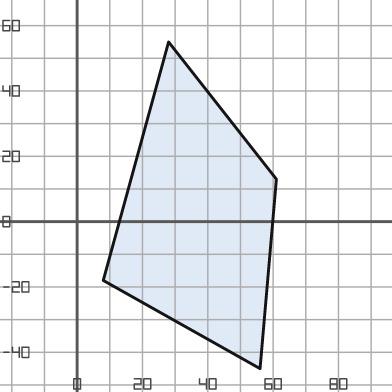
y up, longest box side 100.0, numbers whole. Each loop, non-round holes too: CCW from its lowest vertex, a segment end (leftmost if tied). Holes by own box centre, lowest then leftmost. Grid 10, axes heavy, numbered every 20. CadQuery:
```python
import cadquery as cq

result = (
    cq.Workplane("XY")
    .moveTo(56.0, -45.0)
    .lineTo(61.0, 13.0)
    .lineTo(28.0, 55.0)
    .lineTo(8.0, -18.0)
    .close()
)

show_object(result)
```